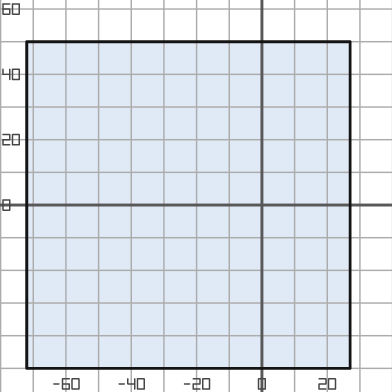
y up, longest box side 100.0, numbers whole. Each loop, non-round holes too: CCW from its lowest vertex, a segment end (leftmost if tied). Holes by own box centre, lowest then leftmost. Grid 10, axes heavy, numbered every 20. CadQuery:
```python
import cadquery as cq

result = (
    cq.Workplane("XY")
    .moveTo(-72.0, -50.0)
    .lineTo(27.0, -50.0)
    .lineTo(27.0, 50.0)
    .lineTo(-72.0, 50.0)
    .close()
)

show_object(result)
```